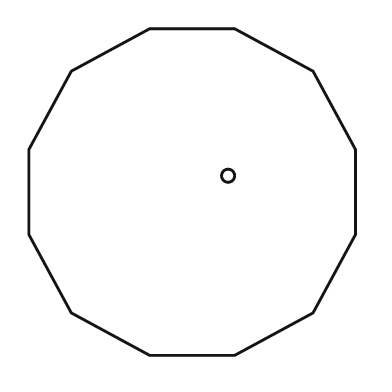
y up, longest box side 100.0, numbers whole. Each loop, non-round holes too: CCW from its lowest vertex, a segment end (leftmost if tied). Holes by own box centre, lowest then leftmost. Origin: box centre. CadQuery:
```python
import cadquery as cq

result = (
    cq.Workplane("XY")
    .moveTo(-13.0, -50.0)
    .lineTo(13.0, -50.0)
    .lineTo(37.0, -37.0)
    .lineTo(50.0, -13.0)
    .lineTo(50.0, 13.0)
    .lineTo(37.0, 37.0)
    .lineTo(13.0, 50.0)
    .lineTo(-13.0, 50.0)
    .lineTo(-37.0, 37.0)
    .lineTo(-50.0, 13.0)
    .lineTo(-50.0, -13.0)
    .lineTo(-37.0, -37.0)
    .close()
    .moveTo(11.0, 5.0)
    .circle(2.0)
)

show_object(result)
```